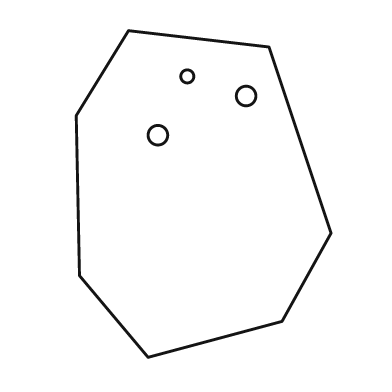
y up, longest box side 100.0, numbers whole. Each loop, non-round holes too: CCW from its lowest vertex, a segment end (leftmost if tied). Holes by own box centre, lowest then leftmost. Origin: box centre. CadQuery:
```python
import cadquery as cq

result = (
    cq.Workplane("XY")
    .moveTo(-17.0, -50.0)
    .lineTo(24.0, -39.0)
    .lineTo(39.0, -12.0)
    .lineTo(20.0, 45.0)
    .lineTo(-23.0, 50.0)
    .lineTo(-39.0, 24.0)
    .lineTo(-38.0, -25.0)
    .close()
    .moveTo(-14.0, 18.0)
    .circle(3.0)
    .moveTo(13.0, 30.0)
    .circle(3.0)
    .moveTo(-5.0, 36.0)
    .circle(2.0)
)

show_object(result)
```